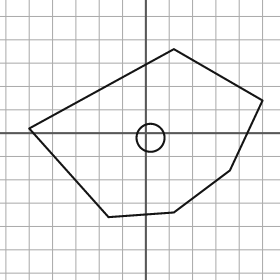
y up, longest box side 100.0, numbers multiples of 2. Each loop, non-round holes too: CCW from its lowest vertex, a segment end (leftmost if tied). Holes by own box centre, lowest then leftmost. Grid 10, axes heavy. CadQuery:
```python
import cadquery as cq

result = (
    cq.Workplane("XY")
    .moveTo(-16.0, -36.0)
    .lineTo(12.0, -34.0)
    .lineTo(36.0, -16.0)
    .lineTo(50.0, 14.0)
    .lineTo(12.0, 36.0)
    .lineTo(-50.0, 2.0)
    .close()
    .moveTo(2.0, -2.0)
    .circle(6.0)
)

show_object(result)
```